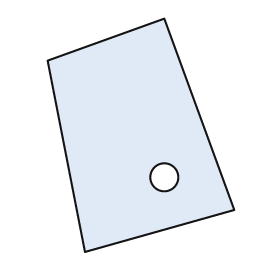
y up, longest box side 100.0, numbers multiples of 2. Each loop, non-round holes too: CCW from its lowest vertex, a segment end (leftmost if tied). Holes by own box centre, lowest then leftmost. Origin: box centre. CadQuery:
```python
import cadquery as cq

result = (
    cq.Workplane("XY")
    .moveTo(-24.0, -50.0)
    .lineTo(40.0, -32.0)
    .lineTo(10.0, 50.0)
    .lineTo(-40.0, 32.0)
    .close()
    .moveTo(10.0, -18.0)
    .circle(6.0)
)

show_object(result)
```